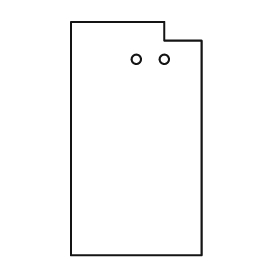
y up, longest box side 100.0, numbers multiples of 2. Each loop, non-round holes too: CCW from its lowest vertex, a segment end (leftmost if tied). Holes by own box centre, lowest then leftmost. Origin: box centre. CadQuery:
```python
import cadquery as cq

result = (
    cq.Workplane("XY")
    .moveTo(-28.0, -50.0)
    .lineTo(28.0, -50.0)
    .lineTo(28.0, 42.0)
    .lineTo(12.0, 42.0)
    .lineTo(12.0, 50.0)
    .lineTo(-28.0, 50.0)
    .close()
    .moveTo(0.0, 34.0)
    .circle(2.0)
    .moveTo(12.0, 34.0)
    .circle(2.0)
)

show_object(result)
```